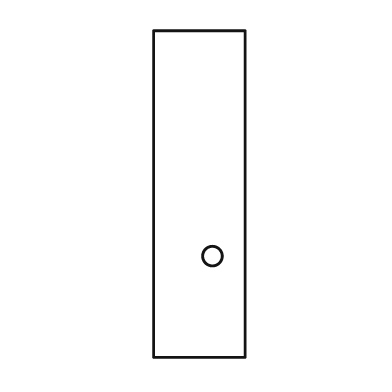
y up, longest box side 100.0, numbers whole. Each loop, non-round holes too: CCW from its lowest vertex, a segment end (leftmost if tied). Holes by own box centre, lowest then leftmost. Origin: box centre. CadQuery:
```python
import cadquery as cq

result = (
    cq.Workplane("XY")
    .moveTo(-14.0, -50.0)
    .lineTo(14.0, -50.0)
    .lineTo(14.0, 50.0)
    .lineTo(-14.0, 50.0)
    .close()
    .moveTo(4.0, -19.0)
    .circle(3.0)
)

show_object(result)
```